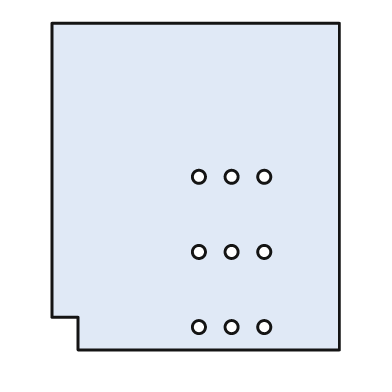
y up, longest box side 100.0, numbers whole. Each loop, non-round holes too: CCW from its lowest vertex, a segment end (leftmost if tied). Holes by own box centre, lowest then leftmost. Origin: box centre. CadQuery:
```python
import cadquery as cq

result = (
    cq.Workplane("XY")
    .moveTo(-36.0, -50.0)
    .lineTo(44.0, -50.0)
    .lineTo(44.0, 50.0)
    .lineTo(-44.0, 50.0)
    .lineTo(-44.0, -40.0)
    .lineTo(-36.0, -40.0)
    .close()
    .moveTo(1.0, -43.0)
    .circle(2.0)
    .moveTo(11.0, -43.0)
    .circle(2.0)
    .moveTo(21.0, -43.0)
    .circle(2.0)
    .moveTo(1.0, -20.0)
    .circle(2.0)
    .moveTo(11.0, -20.0)
    .circle(2.0)
    .moveTo(21.0, -20.0)
    .circle(2.0)
    .moveTo(1.0, 3.0)
    .circle(2.0)
    .moveTo(11.0, 3.0)
    .circle(2.0)
    .moveTo(21.0, 3.0)
    .circle(2.0)
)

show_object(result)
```